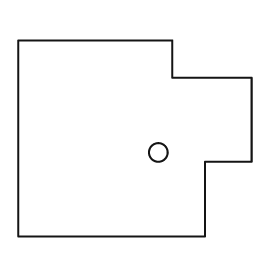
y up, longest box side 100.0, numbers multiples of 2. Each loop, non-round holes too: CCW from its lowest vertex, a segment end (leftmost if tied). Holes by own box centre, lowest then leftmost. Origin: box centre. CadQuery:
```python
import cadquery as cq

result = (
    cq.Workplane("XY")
    .moveTo(-50.0, -42.0)
    .lineTo(30.0, -42.0)
    .lineTo(30.0, -10.0)
    .lineTo(50.0, -10.0)
    .lineTo(50.0, 26.0)
    .lineTo(16.0, 26.0)
    .lineTo(16.0, 42.0)
    .lineTo(-50.0, 42.0)
    .close()
    .moveTo(10.0, -6.0)
    .circle(4.0)
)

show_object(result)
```